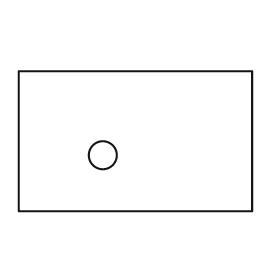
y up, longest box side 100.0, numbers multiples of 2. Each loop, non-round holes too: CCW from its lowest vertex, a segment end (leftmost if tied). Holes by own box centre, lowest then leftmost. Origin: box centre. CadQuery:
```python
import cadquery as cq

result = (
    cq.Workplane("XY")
    .moveTo(-50.0, -30.0)
    .lineTo(50.0, -30.0)
    .lineTo(50.0, 30.0)
    .lineTo(-50.0, 30.0)
    .close()
    .moveTo(-14.0, -6.0)
    .circle(6.0)
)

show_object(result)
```